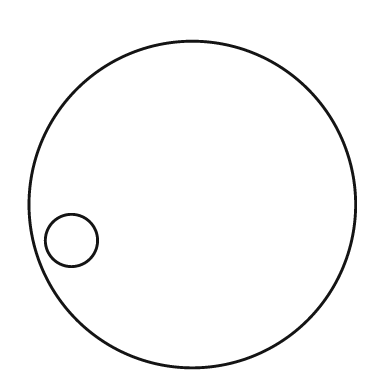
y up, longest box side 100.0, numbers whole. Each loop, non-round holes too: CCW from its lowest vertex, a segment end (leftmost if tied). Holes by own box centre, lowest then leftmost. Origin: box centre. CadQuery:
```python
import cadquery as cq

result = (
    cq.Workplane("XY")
    .moveTo(0.0, 0.0)
    .circle(50.0)
    .moveTo(-37.0, -11.0)
    .circle(8.0)
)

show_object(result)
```